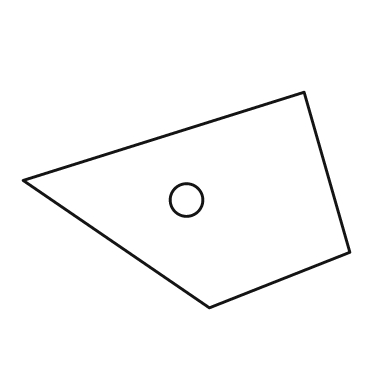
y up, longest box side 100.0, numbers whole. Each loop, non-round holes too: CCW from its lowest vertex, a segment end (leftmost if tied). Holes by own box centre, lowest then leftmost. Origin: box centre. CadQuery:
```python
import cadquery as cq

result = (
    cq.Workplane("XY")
    .moveTo(7.0, -33.0)
    .lineTo(50.0, -16.0)
    .lineTo(36.0, 33.0)
    .lineTo(-50.0, 6.0)
    .close()
    .moveTo(0.0, 0.0)
    .circle(5.0)
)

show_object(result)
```